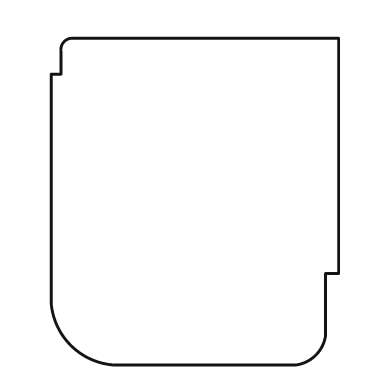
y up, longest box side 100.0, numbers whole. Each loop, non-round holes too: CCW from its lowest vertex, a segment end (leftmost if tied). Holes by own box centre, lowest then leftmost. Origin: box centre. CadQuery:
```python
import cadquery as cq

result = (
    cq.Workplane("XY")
    .moveTo(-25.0, -50.0)
    .lineTo(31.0, -50.0)
    .threePointArc((37.0, -47.0), (40.0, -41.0))
    .lineTo(40.0, -22.0)
    .lineTo(44.0, -22.0)
    .lineTo(44.0, 50.0)
    .lineTo(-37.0, 50.0)
    .threePointArc((-40.0, 49.0), (-41.0, 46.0))
    .lineTo(-41.0, 39.0)
    .lineTo(-44.0, 39.0)
    .lineTo(-44.0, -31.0)
    .threePointArc((-38.0, -44.0), (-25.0, -50.0))
    .close()
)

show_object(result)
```